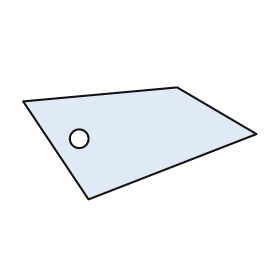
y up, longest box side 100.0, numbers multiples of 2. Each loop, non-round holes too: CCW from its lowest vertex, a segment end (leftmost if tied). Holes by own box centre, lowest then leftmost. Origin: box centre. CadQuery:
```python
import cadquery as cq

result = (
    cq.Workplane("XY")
    .moveTo(-22.0, -24.0)
    .lineTo(50.0, 4.0)
    .lineTo(16.0, 24.0)
    .lineTo(-50.0, 18.0)
    .close()
    .moveTo(-26.0, 2.0)
    .circle(4.0)
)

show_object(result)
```